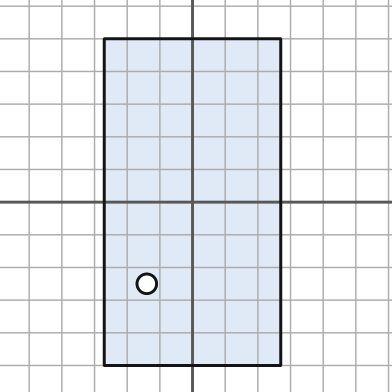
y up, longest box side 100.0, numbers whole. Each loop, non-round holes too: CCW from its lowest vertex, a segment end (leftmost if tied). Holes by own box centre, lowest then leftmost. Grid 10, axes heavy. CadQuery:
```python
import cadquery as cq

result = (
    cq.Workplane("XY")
    .moveTo(-27.0, -50.0)
    .lineTo(27.0, -50.0)
    .lineTo(27.0, 50.0)
    .lineTo(-27.0, 50.0)
    .close()
    .moveTo(-14.0, -25.0)
    .circle(3.0)
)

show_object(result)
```